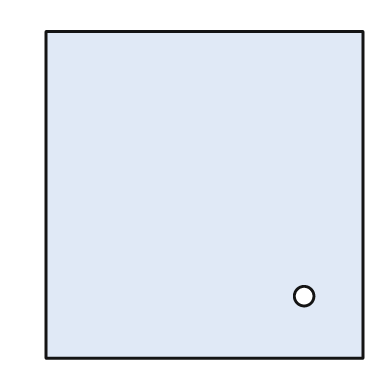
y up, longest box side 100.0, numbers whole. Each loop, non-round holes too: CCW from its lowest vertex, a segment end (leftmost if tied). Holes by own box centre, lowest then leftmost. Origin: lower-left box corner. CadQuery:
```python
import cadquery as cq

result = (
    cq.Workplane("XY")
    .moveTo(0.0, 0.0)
    .lineTo(97.0, 0.0)
    .lineTo(97.0, 100.0)
    .lineTo(0.0, 100.0)
    .close()
    .moveTo(79.0, 19.0)
    .circle(3.0)
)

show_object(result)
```